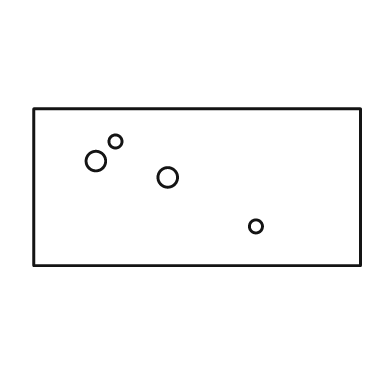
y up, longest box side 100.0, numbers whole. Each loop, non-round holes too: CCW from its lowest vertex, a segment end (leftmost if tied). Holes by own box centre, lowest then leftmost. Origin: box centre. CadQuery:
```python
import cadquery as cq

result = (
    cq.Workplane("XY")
    .moveTo(-50.0, -24.0)
    .lineTo(50.0, -24.0)
    .lineTo(50.0, 24.0)
    .lineTo(-50.0, 24.0)
    .close()
    .moveTo(18.0, -12.0)
    .circle(2.0)
    .moveTo(-9.0, 3.0)
    .circle(3.0)
    .moveTo(-31.0, 8.0)
    .circle(3.0)
    .moveTo(-25.0, 14.0)
    .circle(2.0)
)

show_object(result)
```